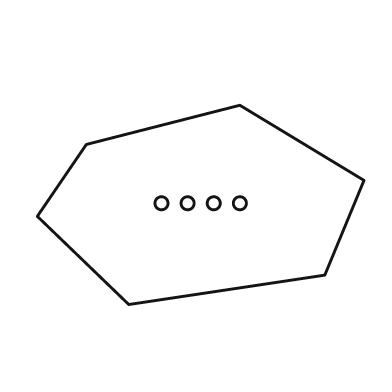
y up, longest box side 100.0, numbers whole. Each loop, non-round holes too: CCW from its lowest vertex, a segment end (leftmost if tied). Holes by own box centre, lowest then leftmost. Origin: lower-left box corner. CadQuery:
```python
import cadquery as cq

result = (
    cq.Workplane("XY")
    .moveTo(28.0, 0.0)
    .lineTo(88.0, 9.0)
    .lineTo(100.0, 38.0)
    .lineTo(62.0, 61.0)
    .lineTo(15.0, 49.0)
    .lineTo(0.0, 27.0)
    .close()
    .moveTo(38.0, 31.0)
    .circle(2.0)
    .moveTo(46.0, 31.0)
    .circle(2.0)
    .moveTo(54.0, 31.0)
    .circle(2.0)
    .moveTo(62.0, 31.0)
    .circle(2.0)
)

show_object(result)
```